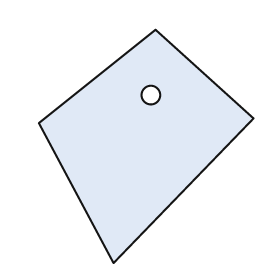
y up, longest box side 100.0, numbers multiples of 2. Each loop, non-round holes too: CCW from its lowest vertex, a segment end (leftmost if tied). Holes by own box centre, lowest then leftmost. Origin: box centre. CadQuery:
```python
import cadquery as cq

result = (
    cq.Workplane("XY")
    .moveTo(-14.0, -50.0)
    .lineTo(46.0, 12.0)
    .lineTo(4.0, 50.0)
    .lineTo(-46.0, 10.0)
    .close()
    .moveTo(2.0, 22.0)
    .circle(4.0)
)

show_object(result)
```